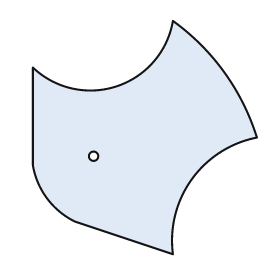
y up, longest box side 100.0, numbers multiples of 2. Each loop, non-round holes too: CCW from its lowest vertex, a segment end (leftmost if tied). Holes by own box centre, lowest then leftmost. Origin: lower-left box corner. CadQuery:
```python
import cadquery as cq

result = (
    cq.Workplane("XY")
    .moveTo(60.0, 0.0)
    .threePointArc((68.0, 32.0), (96.0, 50.0))
    .threePointArc((82.0, 78.0), (60.0, 100.0))
    .threePointArc((36.0, 72.0), (0.0, 80.0))
    .lineTo(0.0, 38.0)
    .threePointArc((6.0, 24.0), (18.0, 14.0))
    .close()
    .moveTo(26.0, 42.0)
    .circle(2.0)
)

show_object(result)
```